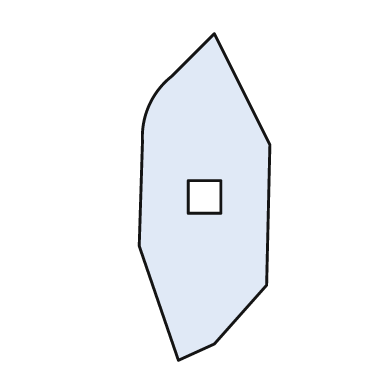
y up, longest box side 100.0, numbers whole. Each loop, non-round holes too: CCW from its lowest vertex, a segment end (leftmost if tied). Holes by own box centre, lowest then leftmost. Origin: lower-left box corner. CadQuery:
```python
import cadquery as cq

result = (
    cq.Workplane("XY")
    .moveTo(12.0, 0.0)
    .lineTo(23.0, 5.0)
    .lineTo(39.0, 23.0)
    .lineTo(40.0, 66.0)
    .lineTo(23.0, 100.0)
    .lineTo(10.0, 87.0)
    .threePointArc((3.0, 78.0), (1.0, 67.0))
    .lineTo(0.0, 35.0)
    .close()
    .moveTo(15.0, 45.0)
    .lineTo(25.0, 45.0)
    .lineTo(25.0, 55.0)
    .lineTo(15.0, 55.0)
    .close()
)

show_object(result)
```